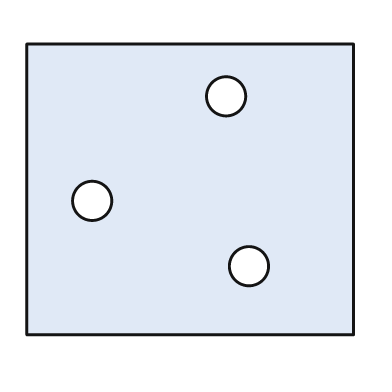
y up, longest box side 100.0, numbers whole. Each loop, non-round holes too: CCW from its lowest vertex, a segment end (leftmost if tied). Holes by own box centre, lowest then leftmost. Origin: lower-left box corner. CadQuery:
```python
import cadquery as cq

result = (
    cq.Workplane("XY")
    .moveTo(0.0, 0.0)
    .lineTo(100.0, 0.0)
    .lineTo(100.0, 89.0)
    .lineTo(0.0, 89.0)
    .close()
    .moveTo(68.0, 21.0)
    .circle(6.0)
    .moveTo(20.0, 41.0)
    .circle(6.0)
    .moveTo(61.0, 73.0)
    .circle(6.0)
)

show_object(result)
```